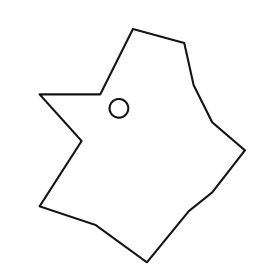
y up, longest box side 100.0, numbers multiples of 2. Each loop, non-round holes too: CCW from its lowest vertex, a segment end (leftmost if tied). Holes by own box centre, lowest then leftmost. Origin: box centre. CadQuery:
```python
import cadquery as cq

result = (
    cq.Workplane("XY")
    .moveTo(2.0, -50.0)
    .lineTo(20.0, -28.0)
    .lineTo(30.0, -20.0)
    .lineTo(44.0, -2.0)
    .lineTo(30.0, 10.0)
    .lineTo(22.0, 26.0)
    .lineTo(18.0, 44.0)
    .lineTo(-4.0, 50.0)
    .lineTo(-18.0, 22.0)
    .lineTo(-44.0, 22.0)
    .lineTo(-26.0, 2.0)
    .lineTo(-44.0, -26.0)
    .lineTo(-20.0, -34.0)
    .close()
    .moveTo(-10.0, 16.0)
    .circle(4.0)
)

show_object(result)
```